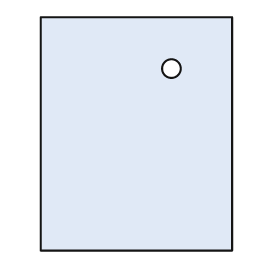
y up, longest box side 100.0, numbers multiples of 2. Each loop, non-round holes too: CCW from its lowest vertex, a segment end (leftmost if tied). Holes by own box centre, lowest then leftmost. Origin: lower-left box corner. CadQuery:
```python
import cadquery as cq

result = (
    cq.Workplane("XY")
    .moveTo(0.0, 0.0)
    .lineTo(82.0, 0.0)
    .lineTo(82.0, 100.0)
    .lineTo(0.0, 100.0)
    .close()
    .moveTo(56.0, 78.0)
    .circle(4.0)
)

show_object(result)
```